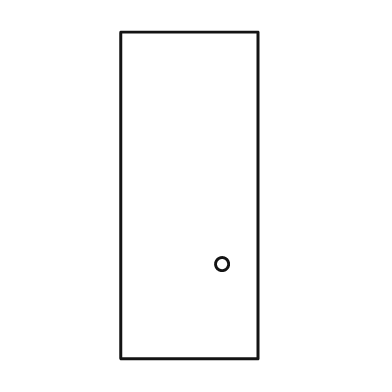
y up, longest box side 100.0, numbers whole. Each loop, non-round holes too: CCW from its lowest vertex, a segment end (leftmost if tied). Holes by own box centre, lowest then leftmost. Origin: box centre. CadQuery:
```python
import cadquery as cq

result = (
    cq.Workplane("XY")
    .moveTo(-21.0, -50.0)
    .lineTo(21.0, -50.0)
    .lineTo(21.0, 50.0)
    .lineTo(-21.0, 50.0)
    .close()
    .moveTo(10.0, -21.0)
    .circle(2.0)
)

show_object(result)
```